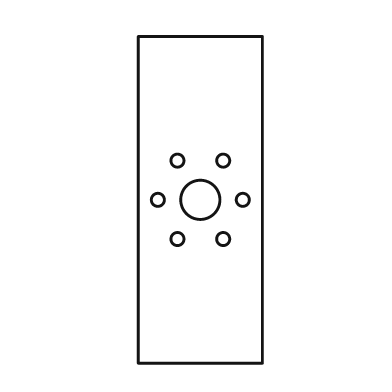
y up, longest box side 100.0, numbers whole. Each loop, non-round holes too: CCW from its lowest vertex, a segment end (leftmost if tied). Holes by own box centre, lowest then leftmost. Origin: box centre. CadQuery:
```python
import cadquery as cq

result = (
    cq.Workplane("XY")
    .moveTo(-19.0, -50.0)
    .lineTo(19.0, -50.0)
    .lineTo(19.0, 50.0)
    .lineTo(-19.0, 50.0)
    .close()
    .moveTo(-7.0, -12.0)
    .circle(2.0)
    .moveTo(7.0, -12.0)
    .circle(2.0)
    .moveTo(-13.0, 0.0)
    .circle(2.0)
    .moveTo(0.0, 0.0)
    .circle(6.0)
    .moveTo(13.0, 0.0)
    .circle(2.0)
    .moveTo(-7.0, 12.0)
    .circle(2.0)
    .moveTo(7.0, 12.0)
    .circle(2.0)
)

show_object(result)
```